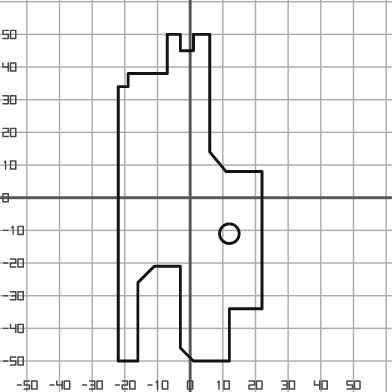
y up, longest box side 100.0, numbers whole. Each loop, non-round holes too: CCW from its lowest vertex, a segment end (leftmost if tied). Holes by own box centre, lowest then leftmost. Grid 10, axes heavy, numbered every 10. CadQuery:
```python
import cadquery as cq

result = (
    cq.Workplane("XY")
    .moveTo(-22.0, -50.0)
    .lineTo(-16.0, -50.0)
    .lineTo(-16.0, -26.0)
    .lineTo(-11.0, -21.0)
    .lineTo(-3.0, -21.0)
    .lineTo(-3.0, -46.0)
    .lineTo(1.0, -50.0)
    .lineTo(12.0, -50.0)
    .lineTo(12.0, -34.0)
    .lineTo(22.0, -34.0)
    .lineTo(22.0, 8.0)
    .lineTo(11.0, 8.0)
    .lineTo(6.0, 14.0)
    .lineTo(6.0, 50.0)
    .lineTo(1.0, 50.0)
    .lineTo(1.0, 45.0)
    .lineTo(-3.0, 45.0)
    .lineTo(-3.0, 50.0)
    .lineTo(-7.0, 50.0)
    .lineTo(-7.0, 38.0)
    .lineTo(-19.0, 38.0)
    .lineTo(-19.0, 34.0)
    .lineTo(-22.0, 34.0)
    .close()
    .moveTo(12.0, -11.0)
    .circle(3.0)
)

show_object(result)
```